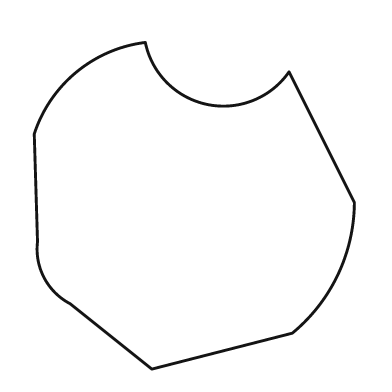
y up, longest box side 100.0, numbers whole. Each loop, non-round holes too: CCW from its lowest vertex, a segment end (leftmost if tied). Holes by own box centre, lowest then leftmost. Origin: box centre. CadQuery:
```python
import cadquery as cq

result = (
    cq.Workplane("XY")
    .moveTo(-13.0, -50.0)
    .lineTo(30.0, -39.0)
    .threePointArc((44.0, -21.0), (49.0, 1.0))
    .lineTo(29.0, 41.0)
    .threePointArc((4.0, 31.0), (-15.0, 50.0))
    .threePointArc((-36.0, 41.0), (-49.0, 22.0))
    .lineTo(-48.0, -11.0)
    .threePointArc((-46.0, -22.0), (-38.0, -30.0))
    .close()
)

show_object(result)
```